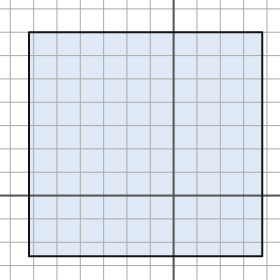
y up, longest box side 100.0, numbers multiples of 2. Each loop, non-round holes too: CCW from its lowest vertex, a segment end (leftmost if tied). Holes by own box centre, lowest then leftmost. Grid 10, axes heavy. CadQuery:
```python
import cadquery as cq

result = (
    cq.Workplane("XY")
    .moveTo(-62.0, -26.0)
    .lineTo(38.0, -26.0)
    .lineTo(38.0, 70.0)
    .lineTo(-62.0, 70.0)
    .close()
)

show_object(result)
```